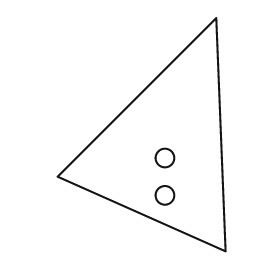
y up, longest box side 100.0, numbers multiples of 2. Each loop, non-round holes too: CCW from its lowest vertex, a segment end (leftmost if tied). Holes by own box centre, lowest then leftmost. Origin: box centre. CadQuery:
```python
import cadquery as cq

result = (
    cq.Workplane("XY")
    .moveTo(36.0, -50.0)
    .lineTo(32.0, 50.0)
    .lineTo(-36.0, -18.0)
    .close()
    .moveTo(10.0, -26.0)
    .circle(4.0)
    .moveTo(10.0, -10.0)
    .circle(4.0)
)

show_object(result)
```